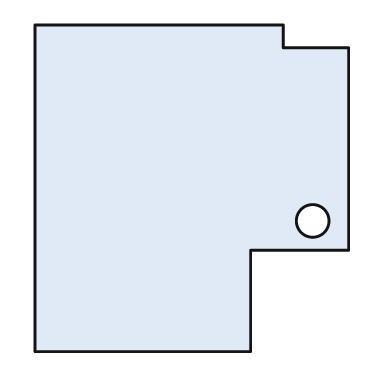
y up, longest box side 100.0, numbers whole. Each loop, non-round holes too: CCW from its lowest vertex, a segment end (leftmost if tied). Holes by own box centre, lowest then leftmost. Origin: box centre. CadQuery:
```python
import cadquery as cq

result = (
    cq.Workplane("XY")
    .moveTo(-48.0, -50.0)
    .lineTo(18.0, -50.0)
    .lineTo(18.0, -19.0)
    .lineTo(48.0, -19.0)
    .lineTo(48.0, 43.0)
    .lineTo(28.0, 43.0)
    .lineTo(28.0, 50.0)
    .lineTo(-48.0, 50.0)
    .close()
    .moveTo(37.0, -10.0)
    .circle(5.0)
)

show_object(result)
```